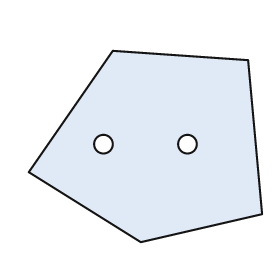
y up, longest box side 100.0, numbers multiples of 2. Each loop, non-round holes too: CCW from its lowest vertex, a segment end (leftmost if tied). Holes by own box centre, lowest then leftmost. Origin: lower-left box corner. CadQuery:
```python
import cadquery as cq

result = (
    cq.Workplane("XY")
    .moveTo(48.0, 0.0)
    .lineTo(100.0, 12.0)
    .lineTo(94.0, 78.0)
    .lineTo(36.0, 82.0)
    .lineTo(0.0, 30.0)
    .close()
    .moveTo(32.0, 42.0)
    .circle(4.0)
    .moveTo(68.0, 42.0)
    .circle(4.0)
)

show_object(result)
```